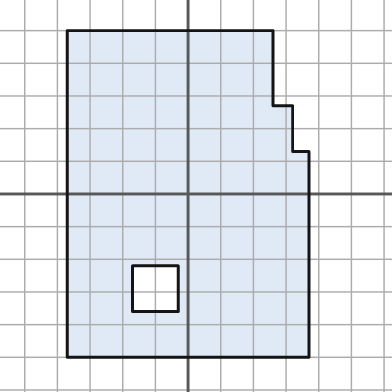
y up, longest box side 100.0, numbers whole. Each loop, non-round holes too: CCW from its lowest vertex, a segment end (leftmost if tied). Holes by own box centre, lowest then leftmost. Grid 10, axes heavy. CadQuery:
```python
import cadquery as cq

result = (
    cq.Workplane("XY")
    .moveTo(-37.0, -50.0)
    .lineTo(37.0, -50.0)
    .lineTo(37.0, 13.0)
    .lineTo(32.0, 13.0)
    .lineTo(32.0, 27.0)
    .lineTo(26.0, 27.0)
    .lineTo(26.0, 50.0)
    .lineTo(-37.0, 50.0)
    .close()
    .moveTo(-17.0, -36.0)
    .lineTo(-3.0, -36.0)
    .lineTo(-3.0, -22.0)
    .lineTo(-17.0, -22.0)
    .close()
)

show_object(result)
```